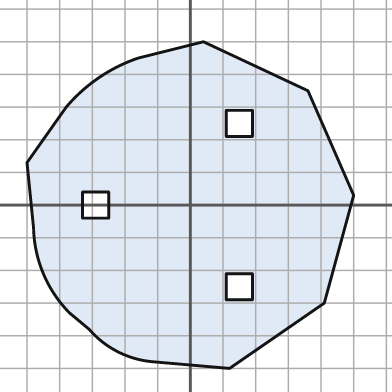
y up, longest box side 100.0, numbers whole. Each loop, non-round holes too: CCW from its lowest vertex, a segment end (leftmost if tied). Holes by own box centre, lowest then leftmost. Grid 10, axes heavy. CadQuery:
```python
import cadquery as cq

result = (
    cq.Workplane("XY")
    .moveTo(12.0, -50.0)
    .lineTo(41.0, -30.0)
    .lineTo(50.0, 3.0)
    .lineTo(36.0, 35.0)
    .lineTo(4.0, 50.0)
    .lineTo(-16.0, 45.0)
    .threePointArc((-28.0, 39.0), (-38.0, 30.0))
    .lineTo(-50.0, 13.0)
    .lineTo(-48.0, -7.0)
    .threePointArc((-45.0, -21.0), (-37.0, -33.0))
    .lineTo(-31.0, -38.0)
    .threePointArc((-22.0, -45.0), (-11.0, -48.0))
    .close()
    .moveTo(11.0, -29.0)
    .lineTo(19.0, -29.0)
    .lineTo(19.0, -21.0)
    .lineTo(11.0, -21.0)
    .close()
    .moveTo(-33.0, -4.0)
    .lineTo(-25.0, -4.0)
    .lineTo(-25.0, 4.0)
    .lineTo(-33.0, 4.0)
    .close()
    .moveTo(11.0, 21.0)
    .lineTo(19.0, 21.0)
    .lineTo(19.0, 29.0)
    .lineTo(11.0, 29.0)
    .close()
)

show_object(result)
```